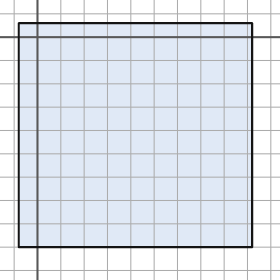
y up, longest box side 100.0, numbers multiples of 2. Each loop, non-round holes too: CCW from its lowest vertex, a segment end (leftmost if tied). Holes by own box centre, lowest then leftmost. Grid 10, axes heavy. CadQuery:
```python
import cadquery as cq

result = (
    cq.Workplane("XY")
    .moveTo(-8.0, -90.0)
    .lineTo(92.0, -90.0)
    .lineTo(92.0, 6.0)
    .lineTo(-8.0, 6.0)
    .close()
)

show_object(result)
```